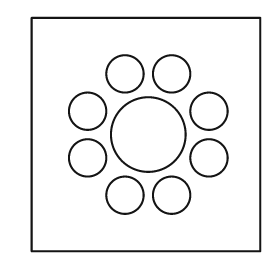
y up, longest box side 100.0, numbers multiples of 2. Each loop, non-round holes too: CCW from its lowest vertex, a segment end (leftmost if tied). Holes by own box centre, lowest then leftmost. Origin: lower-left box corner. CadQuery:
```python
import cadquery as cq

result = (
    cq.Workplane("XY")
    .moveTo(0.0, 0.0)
    .lineTo(98.0, 0.0)
    .lineTo(98.0, 100.0)
    .lineTo(0.0, 100.0)
    .close()
    .moveTo(40.0, 24.0)
    .circle(8.0)
    .moveTo(60.0, 24.0)
    .circle(8.0)
    .moveTo(24.0, 40.0)
    .circle(8.0)
    .moveTo(76.0, 40.0)
    .circle(8.0)
    .moveTo(50.0, 50.0)
    .circle(16.0)
    .moveTo(24.0, 60.0)
    .circle(8.0)
    .moveTo(76.0, 60.0)
    .circle(8.0)
    .moveTo(40.0, 76.0)
    .circle(8.0)
    .moveTo(60.0, 76.0)
    .circle(8.0)
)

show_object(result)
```